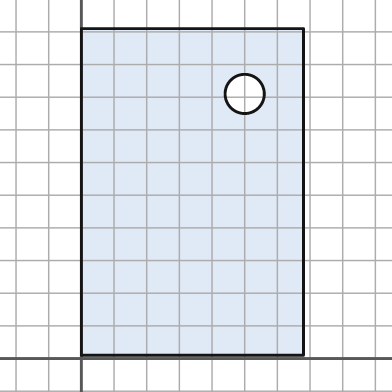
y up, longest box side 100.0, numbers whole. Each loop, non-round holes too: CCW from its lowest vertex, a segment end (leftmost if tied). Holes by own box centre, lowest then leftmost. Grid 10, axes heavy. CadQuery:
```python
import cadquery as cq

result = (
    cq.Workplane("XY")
    .moveTo(0.0, 1.0)
    .lineTo(68.0, 1.0)
    .lineTo(68.0, 101.0)
    .lineTo(0.0, 101.0)
    .close()
    .moveTo(50.0, 81.0)
    .circle(6.0)
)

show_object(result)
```